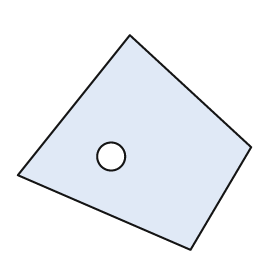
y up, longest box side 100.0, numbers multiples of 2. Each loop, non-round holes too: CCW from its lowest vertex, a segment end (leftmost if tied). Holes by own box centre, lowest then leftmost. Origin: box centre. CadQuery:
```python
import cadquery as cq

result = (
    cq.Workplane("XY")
    .moveTo(24.0, -46.0)
    .lineTo(50.0, -2.0)
    .lineTo(-2.0, 46.0)
    .lineTo(-50.0, -14.0)
    .close()
    .moveTo(-10.0, -6.0)
    .circle(6.0)
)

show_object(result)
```